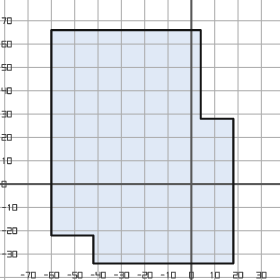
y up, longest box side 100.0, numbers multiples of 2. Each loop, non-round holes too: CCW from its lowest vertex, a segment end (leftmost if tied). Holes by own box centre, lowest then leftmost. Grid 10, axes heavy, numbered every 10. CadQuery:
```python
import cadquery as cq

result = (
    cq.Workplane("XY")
    .moveTo(-42.0, -34.0)
    .lineTo(18.0, -34.0)
    .lineTo(18.0, 28.0)
    .lineTo(4.0, 28.0)
    .lineTo(4.0, 66.0)
    .lineTo(-60.0, 66.0)
    .lineTo(-60.0, -22.0)
    .lineTo(-42.0, -22.0)
    .close()
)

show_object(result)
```